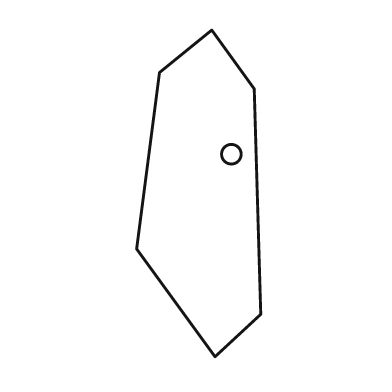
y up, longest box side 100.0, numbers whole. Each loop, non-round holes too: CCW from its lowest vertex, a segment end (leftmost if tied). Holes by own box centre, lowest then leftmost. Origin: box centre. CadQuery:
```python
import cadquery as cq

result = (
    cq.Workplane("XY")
    .moveTo(5.0, -50.0)
    .lineTo(19.0, -37.0)
    .lineTo(17.0, 32.0)
    .lineTo(4.0, 50.0)
    .lineTo(-12.0, 37.0)
    .lineTo(-19.0, -17.0)
    .close()
    .moveTo(10.0, 12.0)
    .circle(3.0)
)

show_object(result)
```